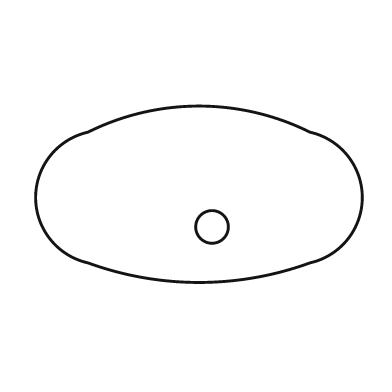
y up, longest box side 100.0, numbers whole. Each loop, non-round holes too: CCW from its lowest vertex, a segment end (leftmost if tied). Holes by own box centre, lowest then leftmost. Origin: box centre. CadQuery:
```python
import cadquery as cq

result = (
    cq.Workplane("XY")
    .moveTo(-34.0, -21.0)
    .threePointArc((0.0, -27.0), (34.0, -21.0))
    .threePointArc((50.0, -1.0), (34.0, 19.0))
    .threePointArc((0.0, 27.0), (-34.0, 19.0))
    .threePointArc((-50.0, -1.0), (-34.0, -21.0))
    .close()
    .moveTo(4.0, -10.0)
    .circle(5.0)
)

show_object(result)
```